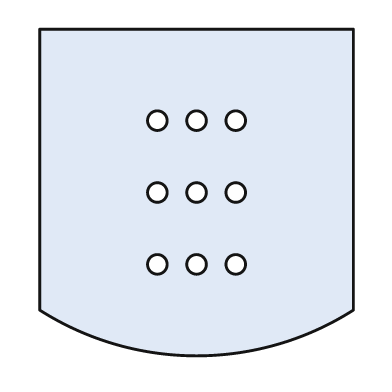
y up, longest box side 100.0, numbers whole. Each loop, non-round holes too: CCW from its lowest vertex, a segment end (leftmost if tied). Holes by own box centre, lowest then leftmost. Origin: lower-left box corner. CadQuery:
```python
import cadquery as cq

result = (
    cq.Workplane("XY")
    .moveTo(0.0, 14.0)
    .threePointArc((48.0, 0.0), (96.0, 14.0))
    .lineTo(96.0, 100.0)
    .lineTo(0.0, 100.0)
    .close()
    .moveTo(36.0, 28.0)
    .circle(3.0)
    .moveTo(48.0, 28.0)
    .circle(3.0)
    .moveTo(60.0, 28.0)
    .circle(3.0)
    .moveTo(36.0, 50.0)
    .circle(3.0)
    .moveTo(48.0, 50.0)
    .circle(3.0)
    .moveTo(60.0, 50.0)
    .circle(3.0)
    .moveTo(36.0, 72.0)
    .circle(3.0)
    .moveTo(48.0, 72.0)
    .circle(3.0)
    .moveTo(60.0, 72.0)
    .circle(3.0)
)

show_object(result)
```